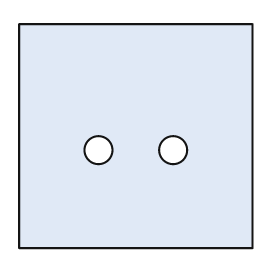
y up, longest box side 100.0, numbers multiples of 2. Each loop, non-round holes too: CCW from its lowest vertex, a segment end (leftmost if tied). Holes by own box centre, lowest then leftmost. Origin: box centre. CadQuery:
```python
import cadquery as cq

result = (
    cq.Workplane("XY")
    .moveTo(-50.0, -48.0)
    .lineTo(50.0, -48.0)
    .lineTo(50.0, 48.0)
    .lineTo(-50.0, 48.0)
    .close()
    .moveTo(-16.0, -6.0)
    .circle(6.0)
    .moveTo(16.0, -6.0)
    .circle(6.0)
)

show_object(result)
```